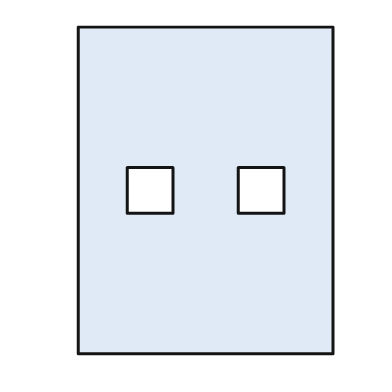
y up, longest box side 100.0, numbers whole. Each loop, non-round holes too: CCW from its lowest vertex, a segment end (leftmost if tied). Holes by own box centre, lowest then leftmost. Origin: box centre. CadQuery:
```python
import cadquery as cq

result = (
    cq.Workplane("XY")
    .moveTo(-39.0, -50.0)
    .lineTo(39.0, -50.0)
    .lineTo(39.0, 50.0)
    .lineTo(-39.0, 50.0)
    .close()
    .moveTo(-24.0, -7.0)
    .lineTo(-10.0, -7.0)
    .lineTo(-10.0, 7.0)
    .lineTo(-24.0, 7.0)
    .close()
    .moveTo(10.0, -7.0)
    .lineTo(24.0, -7.0)
    .lineTo(24.0, 7.0)
    .lineTo(10.0, 7.0)
    .close()
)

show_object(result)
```